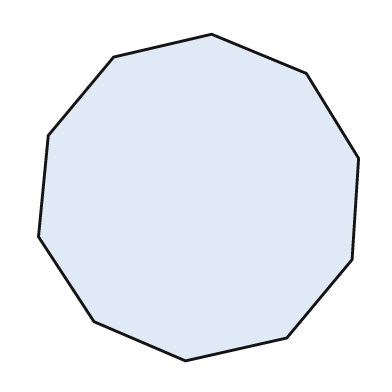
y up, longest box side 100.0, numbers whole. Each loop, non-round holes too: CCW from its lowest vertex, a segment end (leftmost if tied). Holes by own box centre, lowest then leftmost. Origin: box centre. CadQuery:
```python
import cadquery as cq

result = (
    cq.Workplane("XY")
    .moveTo(-4.0, -50.0)
    .lineTo(27.0, -43.0)
    .lineTo(47.0, -19.0)
    .lineTo(49.0, 12.0)
    .lineTo(33.0, 38.0)
    .lineTo(4.0, 50.0)
    .lineTo(-26.0, 43.0)
    .lineTo(-46.0, 19.0)
    .lineTo(-49.0, -12.0)
    .lineTo(-32.0, -38.0)
    .close()
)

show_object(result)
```